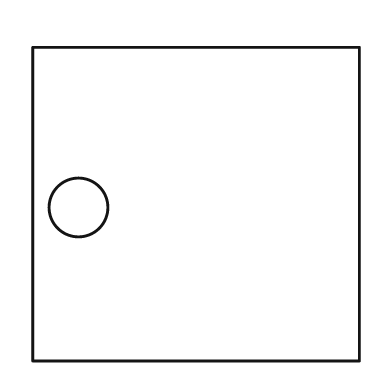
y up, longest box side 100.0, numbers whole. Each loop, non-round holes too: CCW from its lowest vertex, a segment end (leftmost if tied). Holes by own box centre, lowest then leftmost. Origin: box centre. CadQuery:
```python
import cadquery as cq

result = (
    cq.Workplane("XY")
    .moveTo(-50.0, -48.0)
    .lineTo(50.0, -48.0)
    .lineTo(50.0, 48.0)
    .lineTo(-50.0, 48.0)
    .close()
    .moveTo(-36.0, -1.0)
    .circle(9.0)
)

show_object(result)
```